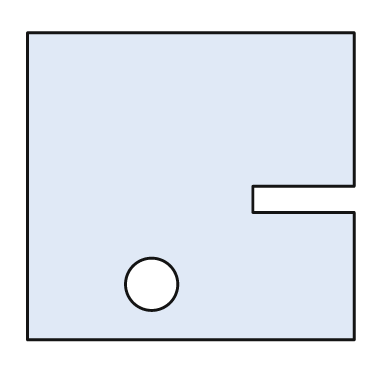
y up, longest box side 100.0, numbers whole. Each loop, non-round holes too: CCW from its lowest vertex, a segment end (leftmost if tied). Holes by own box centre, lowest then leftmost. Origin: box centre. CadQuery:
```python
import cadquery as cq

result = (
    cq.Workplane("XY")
    .moveTo(-50.0, -47.0)
    .lineTo(50.0, -47.0)
    .lineTo(50.0, -8.0)
    .lineTo(19.0, -8.0)
    .lineTo(19.0, 0.0)
    .lineTo(50.0, 0.0)
    .lineTo(50.0, 47.0)
    .lineTo(-50.0, 47.0)
    .close()
    .moveTo(-12.0, -30.0)
    .circle(8.0)
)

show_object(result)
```